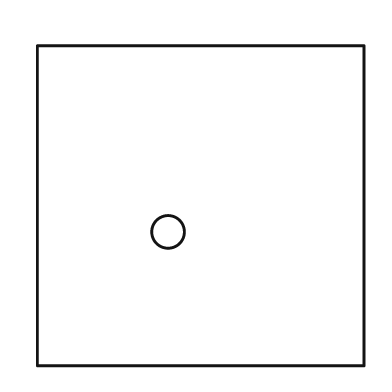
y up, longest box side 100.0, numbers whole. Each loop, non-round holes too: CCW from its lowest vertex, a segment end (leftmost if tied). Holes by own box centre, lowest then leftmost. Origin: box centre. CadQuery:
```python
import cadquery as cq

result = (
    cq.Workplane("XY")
    .moveTo(-50.0, -49.0)
    .lineTo(50.0, -49.0)
    .lineTo(50.0, 49.0)
    .lineTo(-50.0, 49.0)
    .close()
    .moveTo(-10.0, -8.0)
    .circle(5.0)
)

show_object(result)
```